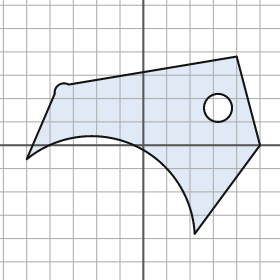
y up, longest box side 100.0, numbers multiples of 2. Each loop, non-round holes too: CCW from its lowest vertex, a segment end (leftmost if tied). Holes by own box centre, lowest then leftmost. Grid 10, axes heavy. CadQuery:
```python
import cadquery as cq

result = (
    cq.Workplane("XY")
    .moveTo(22.0, -38.0)
    .lineTo(50.0, 0.0)
    .lineTo(40.0, 38.0)
    .lineTo(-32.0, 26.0)
    .threePointArc((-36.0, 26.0), (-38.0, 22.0))
    .lineTo(-50.0, -6.0)
    .threePointArc((-4.0, 0.0), (22.0, -38.0))
    .close()
    .moveTo(32.0, 16.0)
    .circle(6.0)
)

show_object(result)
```